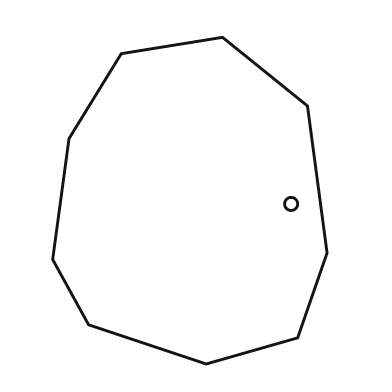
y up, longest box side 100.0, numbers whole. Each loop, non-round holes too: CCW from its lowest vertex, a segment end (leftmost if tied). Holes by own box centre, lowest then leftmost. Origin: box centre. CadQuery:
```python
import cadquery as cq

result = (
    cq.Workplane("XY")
    .moveTo(5.0, -50.0)
    .lineTo(33.0, -42.0)
    .lineTo(42.0, -16.0)
    .lineTo(36.0, 29.0)
    .lineTo(10.0, 50.0)
    .lineTo(-21.0, 45.0)
    .lineTo(-37.0, 19.0)
    .lineTo(-42.0, -18.0)
    .lineTo(-31.0, -38.0)
    .close()
    .moveTo(31.0, -1.0)
    .circle(2.0)
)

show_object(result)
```